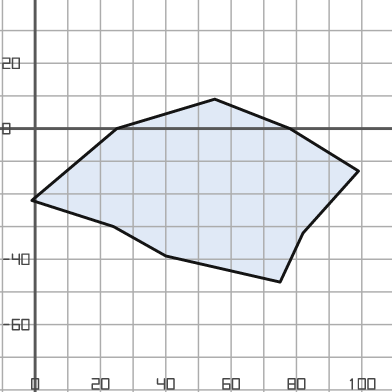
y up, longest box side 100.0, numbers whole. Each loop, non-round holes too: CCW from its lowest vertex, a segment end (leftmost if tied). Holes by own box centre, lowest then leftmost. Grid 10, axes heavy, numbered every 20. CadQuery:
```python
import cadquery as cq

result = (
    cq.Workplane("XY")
    .moveTo(75.0, -47.0)
    .lineTo(82.0, -32.0)
    .lineTo(99.0, -13.0)
    .lineTo(78.0, 0.0)
    .lineTo(55.0, 9.0)
    .lineTo(25.0, 0.0)
    .lineTo(-1.0, -22.0)
    .lineTo(24.0, -30.0)
    .lineTo(40.0, -39.0)
    .close()
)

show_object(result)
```